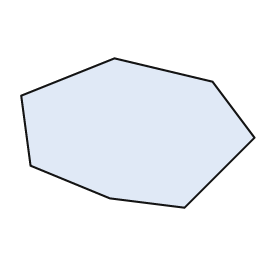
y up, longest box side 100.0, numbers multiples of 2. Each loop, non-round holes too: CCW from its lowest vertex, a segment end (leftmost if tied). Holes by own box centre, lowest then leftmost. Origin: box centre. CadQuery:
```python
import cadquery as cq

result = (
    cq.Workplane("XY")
    .moveTo(20.0, -32.0)
    .lineTo(50.0, -2.0)
    .lineTo(32.0, 22.0)
    .lineTo(-10.0, 32.0)
    .lineTo(-50.0, 16.0)
    .lineTo(-46.0, -14.0)
    .lineTo(-12.0, -28.0)
    .close()
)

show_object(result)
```